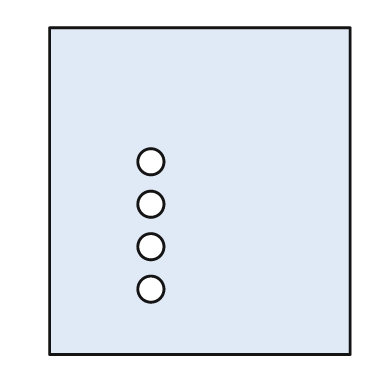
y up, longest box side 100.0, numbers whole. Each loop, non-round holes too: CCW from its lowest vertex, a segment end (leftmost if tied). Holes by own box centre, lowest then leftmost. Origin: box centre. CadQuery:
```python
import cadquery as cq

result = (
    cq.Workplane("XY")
    .moveTo(-46.0, -50.0)
    .lineTo(46.0, -50.0)
    .lineTo(46.0, 50.0)
    .lineTo(-46.0, 50.0)
    .close()
    .moveTo(-15.0, -30.0)
    .circle(4.0)
    .moveTo(-15.0, -17.0)
    .circle(4.0)
    .moveTo(-15.0, -4.0)
    .circle(4.0)
    .moveTo(-15.0, 9.0)
    .circle(4.0)
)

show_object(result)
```